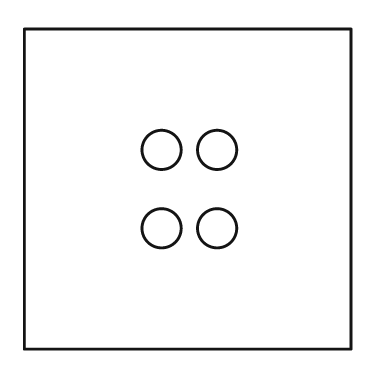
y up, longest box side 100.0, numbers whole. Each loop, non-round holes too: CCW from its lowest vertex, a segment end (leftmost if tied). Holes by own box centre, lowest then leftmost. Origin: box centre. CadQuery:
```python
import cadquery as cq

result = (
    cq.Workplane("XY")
    .moveTo(-50.0, -49.0)
    .lineTo(50.0, -49.0)
    .lineTo(50.0, 49.0)
    .lineTo(-50.0, 49.0)
    .close()
    .moveTo(-8.0, -12.0)
    .circle(6.0)
    .moveTo(9.0, -12.0)
    .circle(6.0)
    .moveTo(-8.0, 12.0)
    .circle(6.0)
    .moveTo(9.0, 12.0)
    .circle(6.0)
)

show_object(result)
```